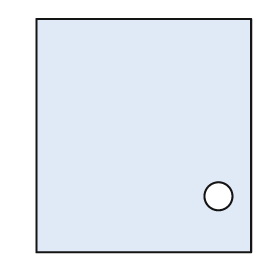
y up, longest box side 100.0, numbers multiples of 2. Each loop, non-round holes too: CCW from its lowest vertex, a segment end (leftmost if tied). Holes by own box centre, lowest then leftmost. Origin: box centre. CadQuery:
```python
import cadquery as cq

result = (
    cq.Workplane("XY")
    .moveTo(-46.0, -50.0)
    .lineTo(46.0, -50.0)
    .lineTo(46.0, 50.0)
    .lineTo(-46.0, 50.0)
    .close()
    .moveTo(32.0, -26.0)
    .circle(6.0)
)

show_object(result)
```